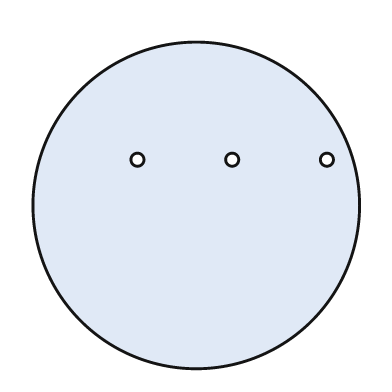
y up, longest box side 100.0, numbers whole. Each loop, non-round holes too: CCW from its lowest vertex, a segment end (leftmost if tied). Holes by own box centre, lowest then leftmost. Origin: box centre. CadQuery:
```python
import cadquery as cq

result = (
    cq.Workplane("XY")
    .moveTo(0.0, 0.0)
    .circle(50.0)
    .moveTo(-18.0, 14.0)
    .circle(2.0)
    .moveTo(11.0, 14.0)
    .circle(2.0)
    .moveTo(40.0, 14.0)
    .circle(2.0)
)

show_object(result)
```